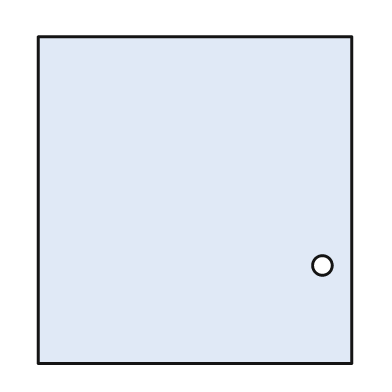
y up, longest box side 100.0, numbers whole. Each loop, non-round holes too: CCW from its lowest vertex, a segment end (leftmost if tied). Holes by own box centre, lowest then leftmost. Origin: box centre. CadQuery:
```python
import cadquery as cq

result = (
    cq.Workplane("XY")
    .moveTo(-48.0, -50.0)
    .lineTo(48.0, -50.0)
    .lineTo(48.0, 50.0)
    .lineTo(-48.0, 50.0)
    .close()
    .moveTo(39.0, -20.0)
    .circle(3.0)
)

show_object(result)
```